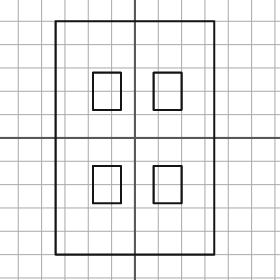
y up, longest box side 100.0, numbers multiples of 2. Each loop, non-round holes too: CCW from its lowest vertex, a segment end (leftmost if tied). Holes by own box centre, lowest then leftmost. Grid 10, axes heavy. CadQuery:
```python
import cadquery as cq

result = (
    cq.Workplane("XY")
    .moveTo(-34.0, -50.0)
    .lineTo(34.0, -50.0)
    .lineTo(34.0, 50.0)
    .lineTo(-34.0, 50.0)
    .close()
    .moveTo(-18.0, -28.0)
    .lineTo(-6.0, -28.0)
    .lineTo(-6.0, -12.0)
    .lineTo(-18.0, -12.0)
    .close()
    .moveTo(8.0, -28.0)
    .lineTo(20.0, -28.0)
    .lineTo(20.0, -12.0)
    .lineTo(8.0, -12.0)
    .close()
    .moveTo(-18.0, 12.0)
    .lineTo(-6.0, 12.0)
    .lineTo(-6.0, 28.0)
    .lineTo(-18.0, 28.0)
    .close()
    .moveTo(8.0, 12.0)
    .lineTo(20.0, 12.0)
    .lineTo(20.0, 28.0)
    .lineTo(8.0, 28.0)
    .close()
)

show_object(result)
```